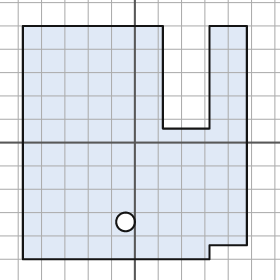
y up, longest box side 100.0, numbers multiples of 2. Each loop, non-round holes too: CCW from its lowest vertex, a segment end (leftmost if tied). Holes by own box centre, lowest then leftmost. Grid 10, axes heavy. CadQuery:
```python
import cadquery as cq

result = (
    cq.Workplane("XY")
    .moveTo(-48.0, -50.0)
    .lineTo(32.0, -50.0)
    .lineTo(32.0, -44.0)
    .lineTo(48.0, -44.0)
    .lineTo(48.0, 50.0)
    .lineTo(32.0, 50.0)
    .lineTo(32.0, 6.0)
    .lineTo(12.0, 6.0)
    .lineTo(12.0, 50.0)
    .lineTo(-48.0, 50.0)
    .close()
    .moveTo(-4.0, -34.0)
    .circle(4.0)
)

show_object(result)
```